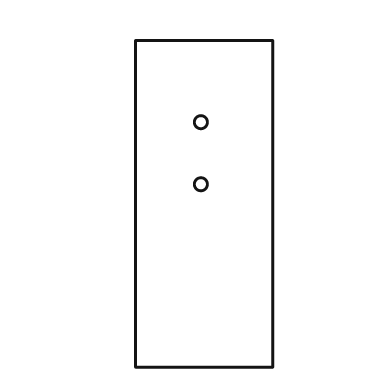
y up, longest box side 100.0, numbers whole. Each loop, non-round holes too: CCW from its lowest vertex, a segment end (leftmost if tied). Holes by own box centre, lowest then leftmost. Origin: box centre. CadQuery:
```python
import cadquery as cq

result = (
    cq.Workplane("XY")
    .moveTo(-21.0, -50.0)
    .lineTo(21.0, -50.0)
    .lineTo(21.0, 50.0)
    .lineTo(-21.0, 50.0)
    .close()
    .moveTo(-1.0, 6.0)
    .circle(2.0)
    .moveTo(-1.0, 25.0)
    .circle(2.0)
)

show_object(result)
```